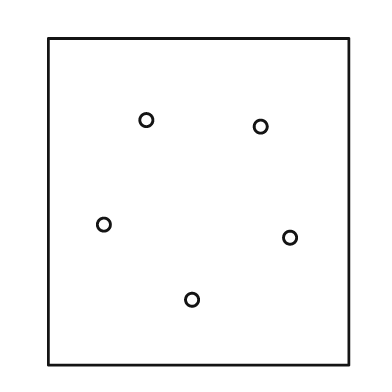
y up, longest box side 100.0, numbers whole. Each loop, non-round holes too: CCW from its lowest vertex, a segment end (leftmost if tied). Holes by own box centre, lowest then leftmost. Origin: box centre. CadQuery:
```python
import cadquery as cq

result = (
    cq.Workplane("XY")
    .moveTo(-46.0, -50.0)
    .lineTo(46.0, -50.0)
    .lineTo(46.0, 50.0)
    .lineTo(-46.0, 50.0)
    .close()
    .moveTo(-2.0, -30.0)
    .circle(2.0)
    .moveTo(28.0, -11.0)
    .circle(2.0)
    .moveTo(-29.0, -7.0)
    .circle(2.0)
    .moveTo(19.0, 23.0)
    .circle(2.0)
    .moveTo(-16.0, 25.0)
    .circle(2.0)
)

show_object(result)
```